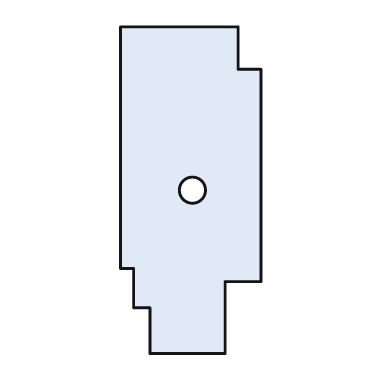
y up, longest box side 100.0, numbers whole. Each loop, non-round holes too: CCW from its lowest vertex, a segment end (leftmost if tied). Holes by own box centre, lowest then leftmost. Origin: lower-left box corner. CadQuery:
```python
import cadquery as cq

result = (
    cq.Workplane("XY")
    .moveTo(9.0, 0.0)
    .lineTo(32.0, 0.0)
    .lineTo(32.0, 22.0)
    .lineTo(43.0, 22.0)
    .lineTo(43.0, 87.0)
    .lineTo(36.0, 87.0)
    .lineTo(36.0, 100.0)
    .lineTo(0.0, 100.0)
    .lineTo(0.0, 26.0)
    .lineTo(4.0, 26.0)
    .lineTo(4.0, 14.0)
    .lineTo(9.0, 14.0)
    .close()
    .moveTo(22.0, 50.0)
    .circle(4.0)
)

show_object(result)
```